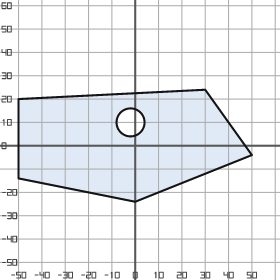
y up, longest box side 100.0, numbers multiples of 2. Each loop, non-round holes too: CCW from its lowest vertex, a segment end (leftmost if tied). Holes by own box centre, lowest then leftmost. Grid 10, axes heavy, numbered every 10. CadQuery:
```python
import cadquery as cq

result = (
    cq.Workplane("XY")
    .moveTo(0.0, -24.0)
    .lineTo(50.0, -4.0)
    .lineTo(30.0, 24.0)
    .lineTo(-50.0, 20.0)
    .lineTo(-50.0, -14.0)
    .close()
    .moveTo(-2.0, 10.0)
    .circle(6.0)
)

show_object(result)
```